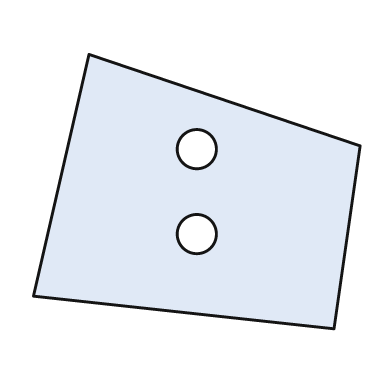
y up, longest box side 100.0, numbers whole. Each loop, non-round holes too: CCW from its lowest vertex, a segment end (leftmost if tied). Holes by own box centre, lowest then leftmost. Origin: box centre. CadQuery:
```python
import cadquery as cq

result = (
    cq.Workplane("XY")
    .moveTo(42.0, -42.0)
    .lineTo(50.0, 14.0)
    .lineTo(-33.0, 42.0)
    .lineTo(-50.0, -32.0)
    .close()
    .moveTo(0.0, -13.0)
    .circle(6.0)
    .moveTo(0.0, 13.0)
    .circle(6.0)
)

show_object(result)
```